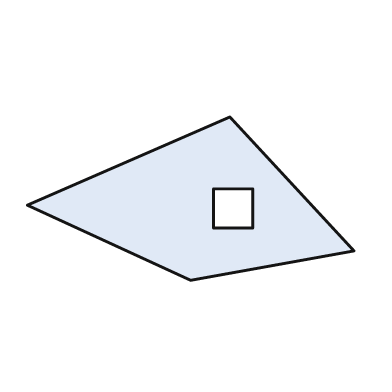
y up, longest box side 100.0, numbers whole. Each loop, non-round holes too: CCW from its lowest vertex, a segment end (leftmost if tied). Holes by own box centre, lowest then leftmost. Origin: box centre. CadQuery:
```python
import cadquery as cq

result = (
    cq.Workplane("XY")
    .moveTo(0.0, -25.0)
    .lineTo(50.0, -16.0)
    .lineTo(12.0, 25.0)
    .lineTo(-50.0, -2.0)
    .close()
    .moveTo(7.0, -9.0)
    .lineTo(19.0, -9.0)
    .lineTo(19.0, 3.0)
    .lineTo(7.0, 3.0)
    .close()
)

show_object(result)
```